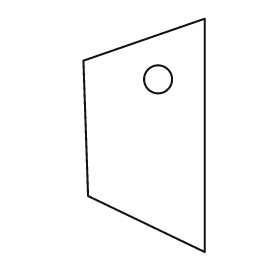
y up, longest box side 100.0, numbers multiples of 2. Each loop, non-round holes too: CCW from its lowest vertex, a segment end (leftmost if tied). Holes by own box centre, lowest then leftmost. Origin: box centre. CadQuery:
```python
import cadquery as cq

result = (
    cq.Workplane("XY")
    .moveTo(26.0, -50.0)
    .lineTo(26.0, 50.0)
    .lineTo(-26.0, 32.0)
    .lineTo(-24.0, -26.0)
    .close()
    .moveTo(6.0, 24.0)
    .circle(6.0)
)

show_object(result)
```